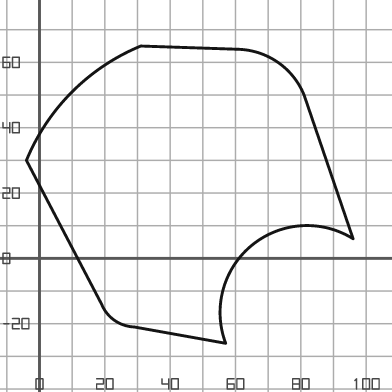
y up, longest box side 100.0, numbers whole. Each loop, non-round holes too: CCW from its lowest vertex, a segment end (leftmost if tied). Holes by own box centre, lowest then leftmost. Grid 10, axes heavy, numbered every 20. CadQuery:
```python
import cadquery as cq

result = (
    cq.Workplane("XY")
    .moveTo(57.0, -26.0)
    .threePointArc((65.0, 4.0), (96.0, 6.0))
    .lineTo(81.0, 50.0)
    .threePointArc((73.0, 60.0), (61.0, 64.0))
    .lineTo(31.0, 65.0)
    .threePointArc((10.0, 51.0), (-4.0, 30.0))
    .lineTo(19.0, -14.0)
    .threePointArc((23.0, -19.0), (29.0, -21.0))
    .close()
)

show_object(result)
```